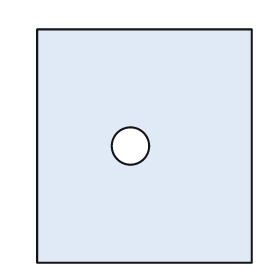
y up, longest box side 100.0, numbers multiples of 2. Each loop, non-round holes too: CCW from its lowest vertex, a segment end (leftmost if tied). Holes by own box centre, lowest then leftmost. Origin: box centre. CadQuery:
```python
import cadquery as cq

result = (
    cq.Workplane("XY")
    .moveTo(-46.0, -50.0)
    .lineTo(46.0, -50.0)
    .lineTo(46.0, 50.0)
    .lineTo(-46.0, 50.0)
    .close()
    .moveTo(-6.0, 0.0)
    .circle(8.0)
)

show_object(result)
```